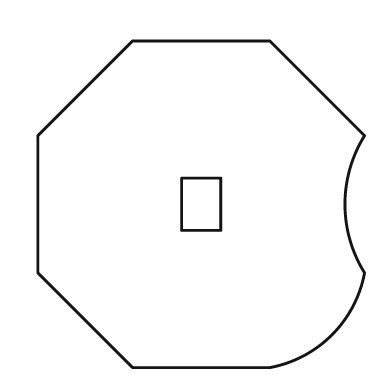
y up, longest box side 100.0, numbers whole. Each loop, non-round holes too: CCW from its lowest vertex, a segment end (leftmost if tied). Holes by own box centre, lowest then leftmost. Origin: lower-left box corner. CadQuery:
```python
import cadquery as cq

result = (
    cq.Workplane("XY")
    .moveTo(29.0, 0.0)
    .lineTo(71.0, 0.0)
    .threePointArc((90.0, 10.0), (100.0, 29.0))
    .threePointArc((94.0, 50.0), (100.0, 71.0))
    .lineTo(71.0, 100.0)
    .lineTo(29.0, 100.0)
    .lineTo(0.0, 71.0)
    .lineTo(0.0, 29.0)
    .close()
    .moveTo(44.0, 42.0)
    .lineTo(56.0, 42.0)
    .lineTo(56.0, 58.0)
    .lineTo(44.0, 58.0)
    .close()
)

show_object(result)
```